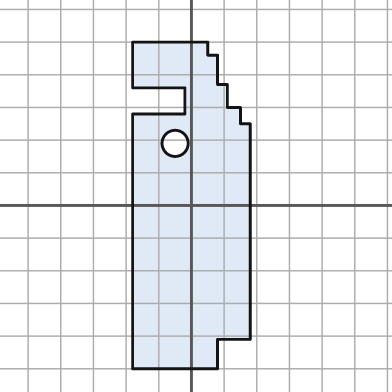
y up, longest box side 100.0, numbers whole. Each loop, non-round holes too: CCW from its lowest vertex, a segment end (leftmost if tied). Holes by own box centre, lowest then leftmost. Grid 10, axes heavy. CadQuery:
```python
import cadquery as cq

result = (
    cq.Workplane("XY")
    .moveTo(-18.0, -50.0)
    .lineTo(8.0, -50.0)
    .lineTo(8.0, -41.0)
    .lineTo(18.0, -41.0)
    .lineTo(18.0, 25.0)
    .lineTo(15.0, 25.0)
    .lineTo(15.0, 30.0)
    .lineTo(11.0, 30.0)
    .lineTo(11.0, 37.0)
    .lineTo(8.0, 37.0)
    .lineTo(8.0, 46.0)
    .lineTo(5.0, 46.0)
    .lineTo(5.0, 50.0)
    .lineTo(-18.0, 50.0)
    .lineTo(-18.0, 36.0)
    .lineTo(-2.0, 36.0)
    .lineTo(-2.0, 28.0)
    .lineTo(-18.0, 28.0)
    .close()
    .moveTo(-5.0, 19.0)
    .circle(4.0)
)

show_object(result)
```